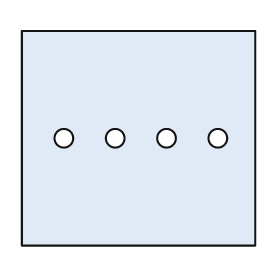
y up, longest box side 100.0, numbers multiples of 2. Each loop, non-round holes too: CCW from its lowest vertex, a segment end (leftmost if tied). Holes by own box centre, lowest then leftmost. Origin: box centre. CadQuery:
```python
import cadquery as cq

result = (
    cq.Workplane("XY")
    .moveTo(-50.0, -46.0)
    .lineTo(50.0, -46.0)
    .lineTo(50.0, 46.0)
    .lineTo(-50.0, 46.0)
    .close()
    .moveTo(-32.0, 0.0)
    .circle(4.0)
    .moveTo(-10.0, 0.0)
    .circle(4.0)
    .moveTo(12.0, 0.0)
    .circle(4.0)
    .moveTo(34.0, 0.0)
    .circle(4.0)
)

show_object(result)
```